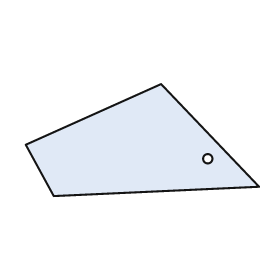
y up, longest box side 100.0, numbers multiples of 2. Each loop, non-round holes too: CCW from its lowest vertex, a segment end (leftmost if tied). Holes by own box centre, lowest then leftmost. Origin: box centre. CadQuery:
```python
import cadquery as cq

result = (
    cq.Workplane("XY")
    .moveTo(-38.0, -24.0)
    .lineTo(50.0, -20.0)
    .lineTo(8.0, 24.0)
    .lineTo(-50.0, -2.0)
    .close()
    .moveTo(28.0, -8.0)
    .circle(2.0)
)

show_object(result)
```